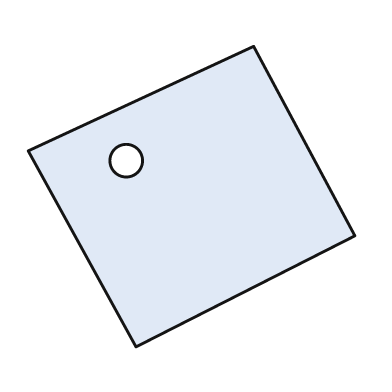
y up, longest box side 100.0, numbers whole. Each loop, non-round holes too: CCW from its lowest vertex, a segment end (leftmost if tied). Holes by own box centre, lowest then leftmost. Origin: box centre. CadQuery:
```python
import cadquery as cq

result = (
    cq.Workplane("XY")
    .moveTo(-17.0, -46.0)
    .lineTo(50.0, -12.0)
    .lineTo(19.0, 46.0)
    .lineTo(-50.0, 14.0)
    .close()
    .moveTo(-20.0, 11.0)
    .circle(5.0)
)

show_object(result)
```